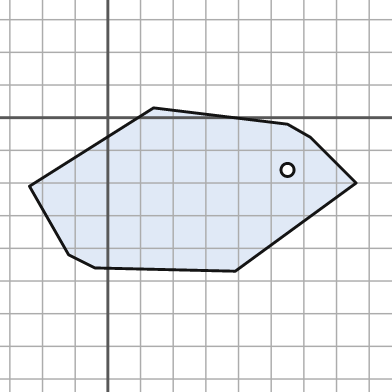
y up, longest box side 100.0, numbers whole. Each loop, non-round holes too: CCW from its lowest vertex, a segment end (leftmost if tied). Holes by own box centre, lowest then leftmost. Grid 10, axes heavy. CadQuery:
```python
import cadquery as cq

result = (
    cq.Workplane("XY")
    .moveTo(39.0, -47.0)
    .lineTo(76.0, -20.0)
    .lineTo(62.0, -6.0)
    .lineTo(55.0, -2.0)
    .lineTo(14.0, 3.0)
    .lineTo(-24.0, -21.0)
    .lineTo(-12.0, -42.0)
    .lineTo(-4.0, -46.0)
    .close()
    .moveTo(55.0, -16.0)
    .circle(2.0)
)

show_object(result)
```